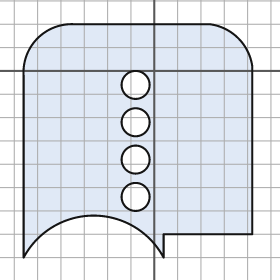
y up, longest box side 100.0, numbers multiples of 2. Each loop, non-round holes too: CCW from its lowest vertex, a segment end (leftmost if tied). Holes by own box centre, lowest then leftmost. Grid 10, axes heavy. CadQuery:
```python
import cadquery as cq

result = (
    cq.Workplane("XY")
    .moveTo(-56.0, -80.0)
    .threePointArc((-26.0, -62.0), (4.0, -80.0))
    .lineTo(4.0, -70.0)
    .lineTo(42.0, -70.0)
    .lineTo(42.0, 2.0)
    .threePointArc((36.0, 14.0), (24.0, 20.0))
    .lineTo(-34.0, 20.0)
    .threePointArc((-50.0, 14.0), (-56.0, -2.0))
    .close()
    .moveTo(-8.0, -54.0)
    .circle(6.0)
    .moveTo(-8.0, -38.0)
    .circle(6.0)
    .moveTo(-8.0, -22.0)
    .circle(6.0)
    .moveTo(-8.0, -6.0)
    .circle(6.0)
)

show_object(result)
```